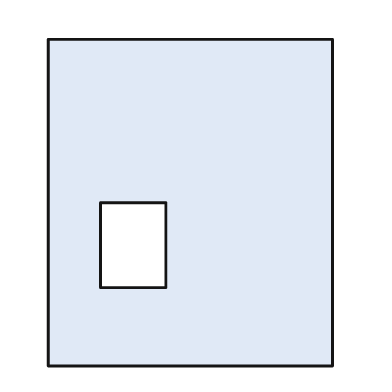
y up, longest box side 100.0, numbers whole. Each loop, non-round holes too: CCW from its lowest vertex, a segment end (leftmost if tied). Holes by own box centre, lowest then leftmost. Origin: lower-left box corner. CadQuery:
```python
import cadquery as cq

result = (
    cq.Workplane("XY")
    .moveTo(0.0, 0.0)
    .lineTo(87.0, 0.0)
    .lineTo(87.0, 100.0)
    .lineTo(0.0, 100.0)
    .close()
    .moveTo(16.0, 24.0)
    .lineTo(36.0, 24.0)
    .lineTo(36.0, 50.0)
    .lineTo(16.0, 50.0)
    .close()
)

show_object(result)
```